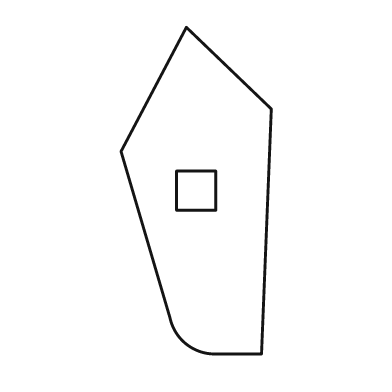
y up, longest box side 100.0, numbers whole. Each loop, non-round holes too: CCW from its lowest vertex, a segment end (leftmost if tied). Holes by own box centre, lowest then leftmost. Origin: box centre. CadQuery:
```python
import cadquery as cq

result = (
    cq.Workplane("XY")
    .moveTo(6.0, -50.0)
    .lineTo(20.0, -50.0)
    .lineTo(23.0, 25.0)
    .lineTo(-3.0, 50.0)
    .lineTo(-23.0, 12.0)
    .lineTo(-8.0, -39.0)
    .threePointArc((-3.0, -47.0), (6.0, -50.0))
    .close()
    .moveTo(-6.0, -6.0)
    .lineTo(6.0, -6.0)
    .lineTo(6.0, 6.0)
    .lineTo(-6.0, 6.0)
    .close()
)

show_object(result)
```